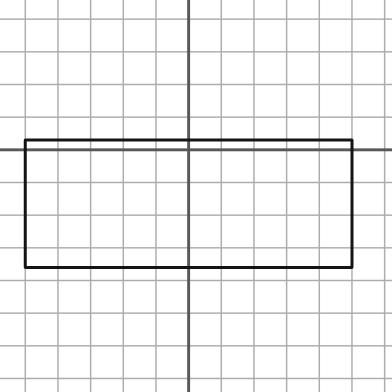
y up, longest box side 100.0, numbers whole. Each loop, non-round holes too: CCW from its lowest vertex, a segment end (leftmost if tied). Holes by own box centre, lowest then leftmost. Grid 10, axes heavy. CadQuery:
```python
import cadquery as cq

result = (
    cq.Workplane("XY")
    .moveTo(-50.0, -36.0)
    .lineTo(50.0, -36.0)
    .lineTo(50.0, 3.0)
    .lineTo(-50.0, 3.0)
    .close()
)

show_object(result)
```